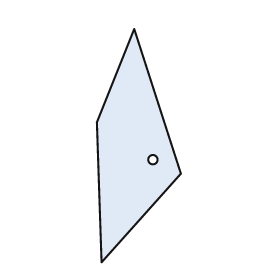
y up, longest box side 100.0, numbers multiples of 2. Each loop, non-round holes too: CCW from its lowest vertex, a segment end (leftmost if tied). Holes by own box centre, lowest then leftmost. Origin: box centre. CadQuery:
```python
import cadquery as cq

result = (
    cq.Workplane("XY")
    .moveTo(-16.0, -50.0)
    .lineTo(18.0, -12.0)
    .lineTo(-2.0, 50.0)
    .lineTo(-18.0, 10.0)
    .close()
    .moveTo(6.0, -6.0)
    .circle(2.0)
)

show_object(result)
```